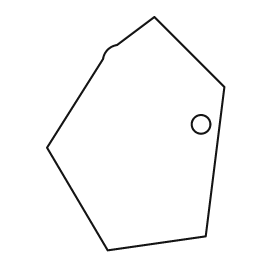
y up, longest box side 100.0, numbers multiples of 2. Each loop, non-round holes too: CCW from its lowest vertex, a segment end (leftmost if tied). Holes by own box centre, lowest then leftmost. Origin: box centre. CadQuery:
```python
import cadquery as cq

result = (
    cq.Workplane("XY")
    .moveTo(-12.0, -50.0)
    .lineTo(30.0, -44.0)
    .lineTo(38.0, 20.0)
    .lineTo(8.0, 50.0)
    .lineTo(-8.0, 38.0)
    .threePointArc((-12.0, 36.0), (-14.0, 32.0))
    .lineTo(-38.0, -6.0)
    .close()
    .moveTo(28.0, 4.0)
    .circle(4.0)
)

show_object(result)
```